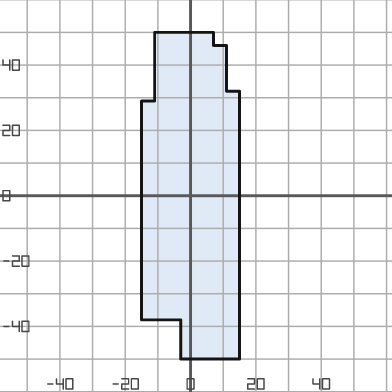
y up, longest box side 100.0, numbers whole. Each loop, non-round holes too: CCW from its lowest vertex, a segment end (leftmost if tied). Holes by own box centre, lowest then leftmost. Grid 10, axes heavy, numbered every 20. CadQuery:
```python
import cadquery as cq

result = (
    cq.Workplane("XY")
    .moveTo(-3.0, -50.0)
    .lineTo(15.0, -50.0)
    .lineTo(15.0, 32.0)
    .lineTo(11.0, 32.0)
    .lineTo(11.0, 46.0)
    .lineTo(7.0, 46.0)
    .lineTo(7.0, 50.0)
    .lineTo(-11.0, 50.0)
    .lineTo(-11.0, 29.0)
    .lineTo(-15.0, 29.0)
    .lineTo(-15.0, -38.0)
    .lineTo(-3.0, -38.0)
    .close()
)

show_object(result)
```